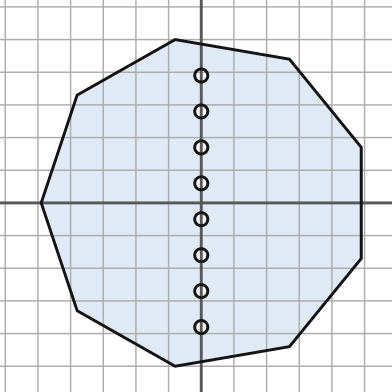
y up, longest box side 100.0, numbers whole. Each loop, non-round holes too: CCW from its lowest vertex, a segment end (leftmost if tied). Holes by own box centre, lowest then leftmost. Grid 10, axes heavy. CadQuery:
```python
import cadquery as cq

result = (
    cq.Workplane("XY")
    .moveTo(-8.0, -50.0)
    .lineTo(27.0, -44.0)
    .lineTo(49.0, -17.0)
    .lineTo(49.0, 17.0)
    .lineTo(27.0, 44.0)
    .lineTo(-8.0, 50.0)
    .lineTo(-38.0, 33.0)
    .lineTo(-49.0, 0.0)
    .lineTo(-38.0, -33.0)
    .close()
    .moveTo(0.0, -38.0)
    .circle(2.0)
    .moveTo(0.0, -27.0)
    .circle(2.0)
    .moveTo(0.0, -16.0)
    .circle(2.0)
    .moveTo(0.0, -5.0)
    .circle(2.0)
    .moveTo(0.0, 6.0)
    .circle(2.0)
    .moveTo(0.0, 17.0)
    .circle(2.0)
    .moveTo(0.0, 28.0)
    .circle(2.0)
    .moveTo(0.0, 39.0)
    .circle(2.0)
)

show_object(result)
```